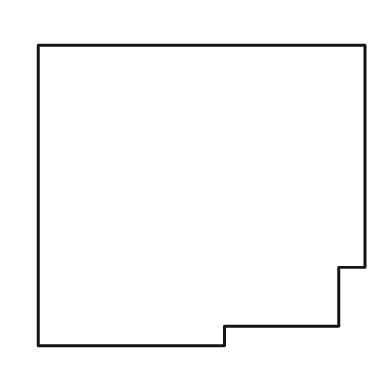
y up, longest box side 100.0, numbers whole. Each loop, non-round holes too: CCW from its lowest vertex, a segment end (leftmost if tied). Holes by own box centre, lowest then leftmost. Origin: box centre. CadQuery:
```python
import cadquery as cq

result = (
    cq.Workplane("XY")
    .moveTo(-50.0, -46.0)
    .lineTo(7.0, -46.0)
    .lineTo(7.0, -40.0)
    .lineTo(42.0, -40.0)
    .lineTo(42.0, -22.0)
    .lineTo(50.0, -22.0)
    .lineTo(50.0, 46.0)
    .lineTo(-50.0, 46.0)
    .close()
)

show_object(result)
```